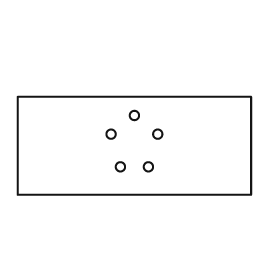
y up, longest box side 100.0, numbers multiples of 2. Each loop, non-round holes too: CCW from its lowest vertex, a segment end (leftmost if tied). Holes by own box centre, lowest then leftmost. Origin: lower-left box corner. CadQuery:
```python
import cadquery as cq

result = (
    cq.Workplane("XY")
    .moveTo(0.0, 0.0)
    .lineTo(100.0, 0.0)
    .lineTo(100.0, 42.0)
    .lineTo(0.0, 42.0)
    .close()
    .moveTo(44.0, 12.0)
    .circle(2.0)
    .moveTo(56.0, 12.0)
    .circle(2.0)
    .moveTo(40.0, 26.0)
    .circle(2.0)
    .moveTo(60.0, 26.0)
    .circle(2.0)
    .moveTo(50.0, 34.0)
    .circle(2.0)
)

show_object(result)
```